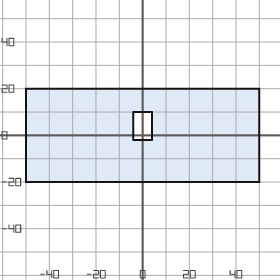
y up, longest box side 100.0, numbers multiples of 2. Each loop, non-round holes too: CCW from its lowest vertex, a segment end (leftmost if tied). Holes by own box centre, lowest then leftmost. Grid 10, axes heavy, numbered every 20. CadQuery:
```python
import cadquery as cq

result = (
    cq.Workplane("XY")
    .moveTo(-50.0, -20.0)
    .lineTo(50.0, -20.0)
    .lineTo(50.0, 20.0)
    .lineTo(-50.0, 20.0)
    .close()
    .moveTo(-4.0, -2.0)
    .lineTo(4.0, -2.0)
    .lineTo(4.0, 10.0)
    .lineTo(-4.0, 10.0)
    .close()
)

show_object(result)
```